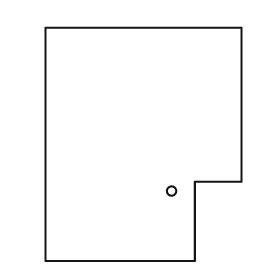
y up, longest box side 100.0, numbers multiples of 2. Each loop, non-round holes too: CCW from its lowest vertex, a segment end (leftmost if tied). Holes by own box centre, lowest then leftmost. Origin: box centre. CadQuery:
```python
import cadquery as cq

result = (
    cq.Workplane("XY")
    .moveTo(-42.0, -50.0)
    .lineTo(22.0, -50.0)
    .lineTo(22.0, -16.0)
    .lineTo(42.0, -16.0)
    .lineTo(42.0, 50.0)
    .lineTo(-42.0, 50.0)
    .close()
    .moveTo(12.0, -20.0)
    .circle(2.0)
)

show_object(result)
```